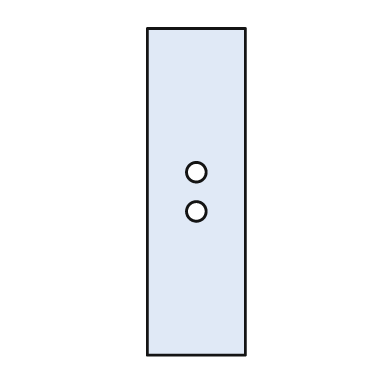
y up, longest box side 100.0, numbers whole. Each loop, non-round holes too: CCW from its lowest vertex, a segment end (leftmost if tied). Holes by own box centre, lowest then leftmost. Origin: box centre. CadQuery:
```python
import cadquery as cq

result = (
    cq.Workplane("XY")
    .moveTo(-15.0, -50.0)
    .lineTo(15.0, -50.0)
    .lineTo(15.0, 50.0)
    .lineTo(-15.0, 50.0)
    .close()
    .moveTo(0.0, -6.0)
    .circle(3.0)
    .moveTo(0.0, 6.0)
    .circle(3.0)
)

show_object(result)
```